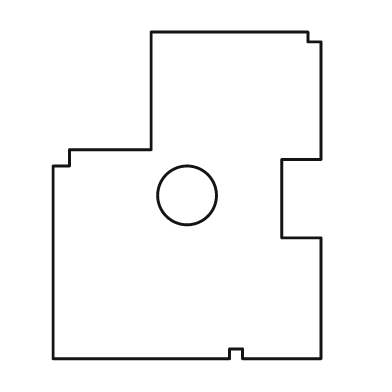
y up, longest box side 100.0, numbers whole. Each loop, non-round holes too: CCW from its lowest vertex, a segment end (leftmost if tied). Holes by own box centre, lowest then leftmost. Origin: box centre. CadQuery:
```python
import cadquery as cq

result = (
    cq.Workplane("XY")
    .moveTo(-41.0, -50.0)
    .lineTo(13.0, -50.0)
    .lineTo(13.0, -47.0)
    .lineTo(17.0, -47.0)
    .lineTo(17.0, -50.0)
    .lineTo(41.0, -50.0)
    .lineTo(41.0, -13.0)
    .lineTo(29.0, -13.0)
    .lineTo(29.0, 11.0)
    .lineTo(41.0, 11.0)
    .lineTo(41.0, 47.0)
    .lineTo(37.0, 47.0)
    .lineTo(37.0, 50.0)
    .lineTo(-11.0, 50.0)
    .lineTo(-11.0, 14.0)
    .lineTo(-36.0, 14.0)
    .lineTo(-36.0, 9.0)
    .lineTo(-41.0, 9.0)
    .close()
    .moveTo(0.0, 0.0)
    .circle(9.0)
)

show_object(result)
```